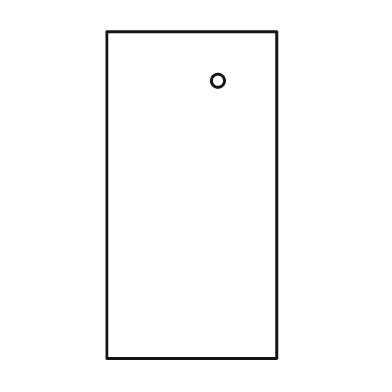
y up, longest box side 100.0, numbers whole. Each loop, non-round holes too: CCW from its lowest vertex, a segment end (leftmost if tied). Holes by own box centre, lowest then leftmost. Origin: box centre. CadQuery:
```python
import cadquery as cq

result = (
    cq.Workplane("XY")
    .moveTo(-26.0, -50.0)
    .lineTo(26.0, -50.0)
    .lineTo(26.0, 50.0)
    .lineTo(-26.0, 50.0)
    .close()
    .moveTo(8.0, 35.0)
    .circle(2.0)
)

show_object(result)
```